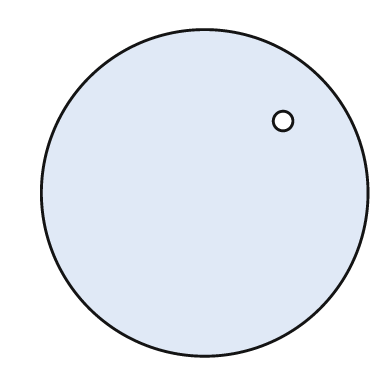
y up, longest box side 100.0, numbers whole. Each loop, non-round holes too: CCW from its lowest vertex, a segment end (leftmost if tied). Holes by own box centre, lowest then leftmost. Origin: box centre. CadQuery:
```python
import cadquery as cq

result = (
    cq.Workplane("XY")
    .moveTo(0.0, 0.0)
    .circle(50.0)
    .moveTo(24.0, 22.0)
    .circle(3.0)
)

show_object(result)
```